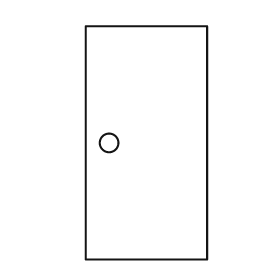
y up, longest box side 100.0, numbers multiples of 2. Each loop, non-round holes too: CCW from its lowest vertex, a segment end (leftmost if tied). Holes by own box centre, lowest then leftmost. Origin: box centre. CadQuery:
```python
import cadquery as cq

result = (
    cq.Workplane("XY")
    .moveTo(-26.0, -50.0)
    .lineTo(26.0, -50.0)
    .lineTo(26.0, 50.0)
    .lineTo(-26.0, 50.0)
    .close()
    .moveTo(-16.0, 0.0)
    .circle(4.0)
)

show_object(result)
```